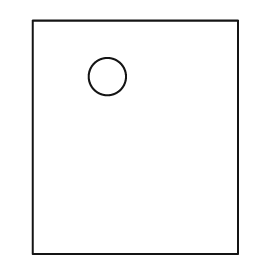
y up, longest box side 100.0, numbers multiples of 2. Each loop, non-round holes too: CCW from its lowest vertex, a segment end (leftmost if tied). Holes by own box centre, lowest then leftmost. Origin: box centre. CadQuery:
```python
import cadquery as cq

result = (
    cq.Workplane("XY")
    .moveTo(-44.0, -50.0)
    .lineTo(44.0, -50.0)
    .lineTo(44.0, 50.0)
    .lineTo(-44.0, 50.0)
    .close()
    .moveTo(-12.0, 26.0)
    .circle(8.0)
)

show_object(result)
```